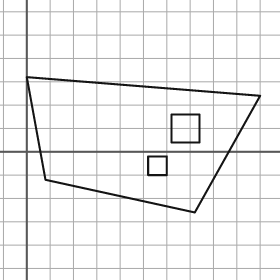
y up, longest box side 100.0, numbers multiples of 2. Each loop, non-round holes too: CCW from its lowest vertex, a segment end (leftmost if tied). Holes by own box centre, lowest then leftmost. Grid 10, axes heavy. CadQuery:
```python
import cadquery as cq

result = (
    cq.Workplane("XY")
    .moveTo(72.0, -26.0)
    .lineTo(100.0, 24.0)
    .lineTo(0.0, 32.0)
    .lineTo(8.0, -12.0)
    .close()
    .moveTo(52.0, -10.0)
    .lineTo(60.0, -10.0)
    .lineTo(60.0, -2.0)
    .lineTo(52.0, -2.0)
    .close()
    .moveTo(62.0, 4.0)
    .lineTo(74.0, 4.0)
    .lineTo(74.0, 16.0)
    .lineTo(62.0, 16.0)
    .close()
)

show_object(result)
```